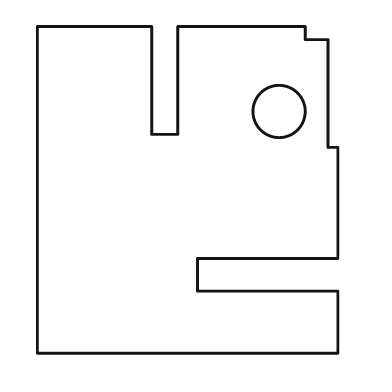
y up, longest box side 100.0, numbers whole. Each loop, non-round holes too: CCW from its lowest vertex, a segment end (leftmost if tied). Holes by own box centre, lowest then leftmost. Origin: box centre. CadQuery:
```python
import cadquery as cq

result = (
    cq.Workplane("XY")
    .moveTo(-46.0, -50.0)
    .lineTo(46.0, -50.0)
    .lineTo(46.0, -31.0)
    .lineTo(3.0, -31.0)
    .lineTo(3.0, -21.0)
    .lineTo(46.0, -21.0)
    .lineTo(46.0, 13.0)
    .lineTo(43.0, 13.0)
    .lineTo(43.0, 46.0)
    .lineTo(36.0, 46.0)
    .lineTo(36.0, 50.0)
    .lineTo(-3.0, 50.0)
    .lineTo(-3.0, 17.0)
    .lineTo(-11.0, 17.0)
    .lineTo(-11.0, 50.0)
    .lineTo(-46.0, 50.0)
    .close()
    .moveTo(28.0, 24.0)
    .circle(8.0)
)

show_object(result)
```